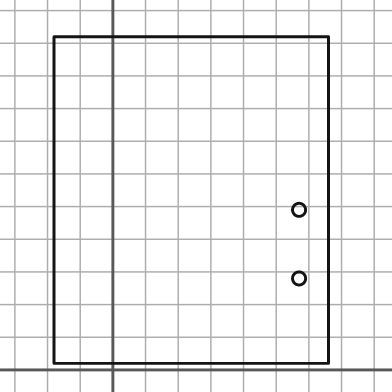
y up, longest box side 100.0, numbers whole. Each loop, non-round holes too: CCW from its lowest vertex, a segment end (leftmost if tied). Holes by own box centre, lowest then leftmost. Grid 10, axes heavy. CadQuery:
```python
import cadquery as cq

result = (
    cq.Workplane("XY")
    .moveTo(-18.0, 2.0)
    .lineTo(66.0, 2.0)
    .lineTo(66.0, 102.0)
    .lineTo(-18.0, 102.0)
    .close()
    .moveTo(57.0, 28.0)
    .circle(2.0)
    .moveTo(57.0, 49.0)
    .circle(2.0)
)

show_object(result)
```